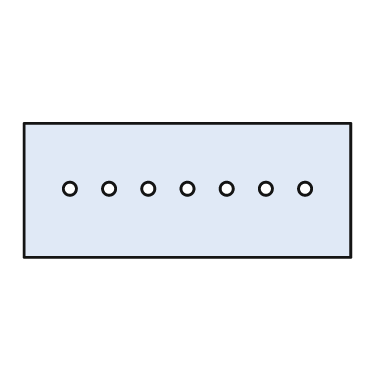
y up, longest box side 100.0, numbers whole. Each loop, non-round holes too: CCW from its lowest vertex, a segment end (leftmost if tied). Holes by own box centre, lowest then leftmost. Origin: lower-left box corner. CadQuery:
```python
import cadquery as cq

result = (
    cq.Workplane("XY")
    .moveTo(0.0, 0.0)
    .lineTo(100.0, 0.0)
    .lineTo(100.0, 41.0)
    .lineTo(0.0, 41.0)
    .close()
    .moveTo(14.0, 21.0)
    .circle(2.0)
    .moveTo(26.0, 21.0)
    .circle(2.0)
    .moveTo(38.0, 21.0)
    .circle(2.0)
    .moveTo(50.0, 21.0)
    .circle(2.0)
    .moveTo(62.0, 21.0)
    .circle(2.0)
    .moveTo(74.0, 21.0)
    .circle(2.0)
    .moveTo(86.0, 21.0)
    .circle(2.0)
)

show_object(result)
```